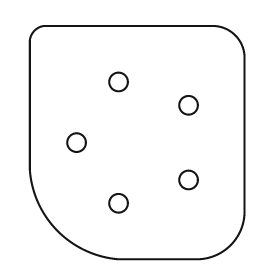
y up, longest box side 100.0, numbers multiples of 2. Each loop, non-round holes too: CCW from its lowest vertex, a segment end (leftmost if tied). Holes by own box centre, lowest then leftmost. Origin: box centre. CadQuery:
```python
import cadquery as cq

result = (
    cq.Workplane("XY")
    .moveTo(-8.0, -50.0)
    .lineTo(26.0, -50.0)
    .threePointArc((40.0, -44.0), (46.0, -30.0))
    .lineTo(46.0, 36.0)
    .threePointArc((42.0, 46.0), (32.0, 50.0))
    .lineTo(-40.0, 50.0)
    .threePointArc((-44.0, 48.0), (-46.0, 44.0))
    .lineTo(-46.0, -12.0)
    .threePointArc((-34.0, -38.0), (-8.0, -50.0))
    .close()
    .moveTo(-8.0, -26.0)
    .circle(4.0)
    .moveTo(22.0, -16.0)
    .circle(4.0)
    .moveTo(-26.0, 0.0)
    .circle(4.0)
    .moveTo(22.0, 16.0)
    .circle(4.0)
    .moveTo(-8.0, 26.0)
    .circle(4.0)
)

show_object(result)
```